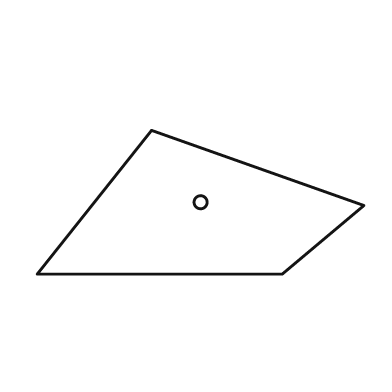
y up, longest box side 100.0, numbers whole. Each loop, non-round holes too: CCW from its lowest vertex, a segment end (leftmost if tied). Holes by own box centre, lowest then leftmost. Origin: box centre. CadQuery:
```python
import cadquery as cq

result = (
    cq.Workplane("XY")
    .moveTo(-50.0, -22.0)
    .lineTo(25.0, -22.0)
    .lineTo(50.0, -1.0)
    .lineTo(-15.0, 22.0)
    .close()
    .moveTo(0.0, 0.0)
    .circle(2.0)
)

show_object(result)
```